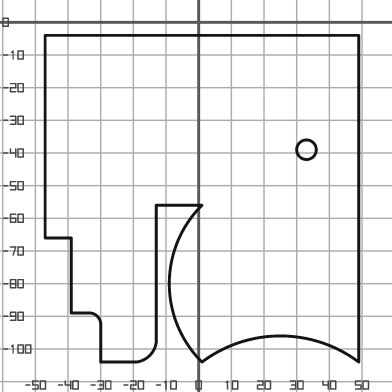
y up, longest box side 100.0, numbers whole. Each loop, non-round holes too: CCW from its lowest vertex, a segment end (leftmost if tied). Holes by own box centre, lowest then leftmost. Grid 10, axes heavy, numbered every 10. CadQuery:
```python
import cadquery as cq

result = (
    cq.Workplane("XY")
    .moveTo(-30.0, -104.0)
    .lineTo(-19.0, -104.0)
    .threePointArc((-15.0, -102.0), (-13.0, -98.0))
    .lineTo(-13.0, -56.0)
    .lineTo(1.0, -56.0)
    .threePointArc((-9.0, -80.0), (1.0, -104.0))
    .threePointArc((25.0, -96.0), (49.0, -104.0))
    .lineTo(49.0, -4.0)
    .lineTo(-47.0, -4.0)
    .lineTo(-47.0, -66.0)
    .lineTo(-39.0, -66.0)
    .lineTo(-39.0, -89.0)
    .lineTo(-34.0, -89.0)
    .threePointArc((-31.0, -90.0), (-30.0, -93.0))
    .close()
    .moveTo(33.0, -39.0)
    .circle(3.0)
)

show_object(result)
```